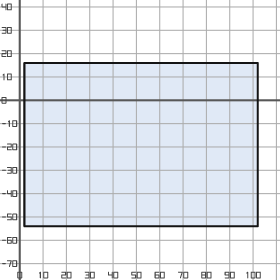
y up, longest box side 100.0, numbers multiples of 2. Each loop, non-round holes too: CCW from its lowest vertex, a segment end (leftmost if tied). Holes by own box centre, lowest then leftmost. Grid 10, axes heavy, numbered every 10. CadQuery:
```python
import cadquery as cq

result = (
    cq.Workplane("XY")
    .moveTo(2.0, -54.0)
    .lineTo(102.0, -54.0)
    .lineTo(102.0, 16.0)
    .lineTo(2.0, 16.0)
    .close()
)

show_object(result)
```